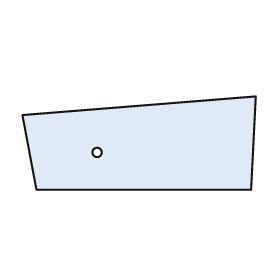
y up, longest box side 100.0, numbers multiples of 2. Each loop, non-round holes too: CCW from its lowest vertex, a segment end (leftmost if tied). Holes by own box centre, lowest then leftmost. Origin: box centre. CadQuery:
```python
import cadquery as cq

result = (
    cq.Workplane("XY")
    .moveTo(-44.0, -20.0)
    .lineTo(48.0, -20.0)
    .lineTo(50.0, 20.0)
    .lineTo(-50.0, 12.0)
    .close()
    .moveTo(-18.0, -4.0)
    .circle(2.0)
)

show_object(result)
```